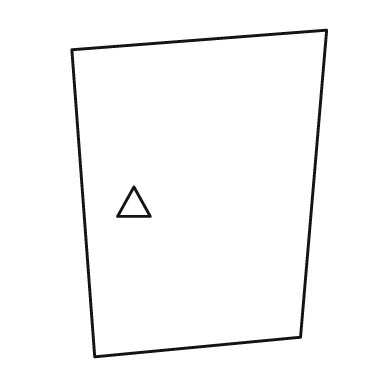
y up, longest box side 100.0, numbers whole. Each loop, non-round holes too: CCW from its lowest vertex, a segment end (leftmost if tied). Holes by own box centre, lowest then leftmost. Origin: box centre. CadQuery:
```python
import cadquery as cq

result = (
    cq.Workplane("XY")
    .moveTo(-32.0, -50.0)
    .lineTo(31.0, -44.0)
    .lineTo(39.0, 50.0)
    .lineTo(-39.0, 44.0)
    .close()
    .moveTo(-25.0, -7.0)
    .lineTo(-15.0, -7.0)
    .lineTo(-20.0, 2.0)
    .close()
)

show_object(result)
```